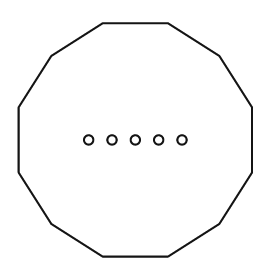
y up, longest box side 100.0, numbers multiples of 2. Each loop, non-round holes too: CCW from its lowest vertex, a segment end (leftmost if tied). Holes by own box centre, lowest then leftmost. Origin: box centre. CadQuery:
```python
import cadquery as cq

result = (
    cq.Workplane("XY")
    .moveTo(-14.0, -50.0)
    .lineTo(14.0, -50.0)
    .lineTo(36.0, -36.0)
    .lineTo(50.0, -14.0)
    .lineTo(50.0, 14.0)
    .lineTo(36.0, 36.0)
    .lineTo(14.0, 50.0)
    .lineTo(-14.0, 50.0)
    .lineTo(-36.0, 36.0)
    .lineTo(-50.0, 14.0)
    .lineTo(-50.0, -14.0)
    .lineTo(-36.0, -36.0)
    .close()
    .moveTo(-20.0, 0.0)
    .circle(2.0)
    .moveTo(-10.0, 0.0)
    .circle(2.0)
    .moveTo(0.0, 0.0)
    .circle(2.0)
    .moveTo(10.0, 0.0)
    .circle(2.0)
    .moveTo(20.0, 0.0)
    .circle(2.0)
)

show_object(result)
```